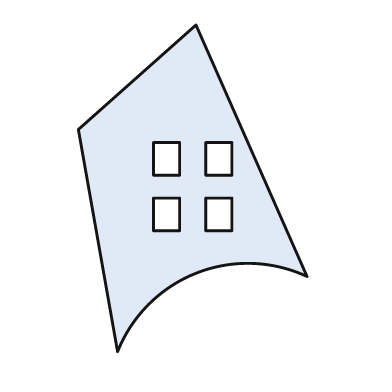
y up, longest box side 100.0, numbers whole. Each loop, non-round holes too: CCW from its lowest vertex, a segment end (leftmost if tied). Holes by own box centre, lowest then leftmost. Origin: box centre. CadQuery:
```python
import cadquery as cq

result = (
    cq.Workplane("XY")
    .moveTo(-23.0, -50.0)
    .threePointArc((1.0, -26.0), (35.0, -27.0))
    .lineTo(1.0, 50.0)
    .lineTo(-35.0, 18.0)
    .close()
    .moveTo(-12.0, -13.0)
    .lineTo(-4.0, -13.0)
    .lineTo(-4.0, -3.0)
    .lineTo(-12.0, -3.0)
    .close()
    .moveTo(4.0, -13.0)
    .lineTo(12.0, -13.0)
    .lineTo(12.0, -3.0)
    .lineTo(4.0, -3.0)
    .close()
    .moveTo(-12.0, 4.0)
    .lineTo(-4.0, 4.0)
    .lineTo(-4.0, 14.0)
    .lineTo(-12.0, 14.0)
    .close()
    .moveTo(4.0, 4.0)
    .lineTo(12.0, 4.0)
    .lineTo(12.0, 14.0)
    .lineTo(4.0, 14.0)
    .close()
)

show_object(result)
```